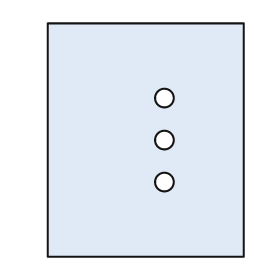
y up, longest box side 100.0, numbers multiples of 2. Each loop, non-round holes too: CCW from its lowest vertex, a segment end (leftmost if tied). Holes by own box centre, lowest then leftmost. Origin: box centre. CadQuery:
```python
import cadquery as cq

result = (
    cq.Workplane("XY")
    .moveTo(-42.0, -50.0)
    .lineTo(42.0, -50.0)
    .lineTo(42.0, 50.0)
    .lineTo(-42.0, 50.0)
    .close()
    .moveTo(8.0, -18.0)
    .circle(4.0)
    .moveTo(8.0, 0.0)
    .circle(4.0)
    .moveTo(8.0, 18.0)
    .circle(4.0)
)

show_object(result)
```